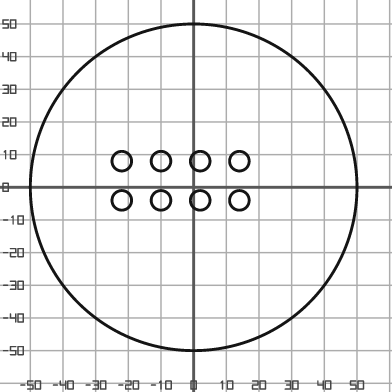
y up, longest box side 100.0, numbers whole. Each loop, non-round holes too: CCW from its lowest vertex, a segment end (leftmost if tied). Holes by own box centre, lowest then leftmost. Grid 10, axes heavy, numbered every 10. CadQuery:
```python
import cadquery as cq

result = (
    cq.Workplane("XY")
    .moveTo(0.0, 0.0)
    .circle(50.0)
    .moveTo(-22.0, -4.0)
    .circle(3.0)
    .moveTo(-10.0, -4.0)
    .circle(3.0)
    .moveTo(2.0, -4.0)
    .circle(3.0)
    .moveTo(14.0, -4.0)
    .circle(3.0)
    .moveTo(-22.0, 8.0)
    .circle(3.0)
    .moveTo(-10.0, 8.0)
    .circle(3.0)
    .moveTo(2.0, 8.0)
    .circle(3.0)
    .moveTo(14.0, 8.0)
    .circle(3.0)
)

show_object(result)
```